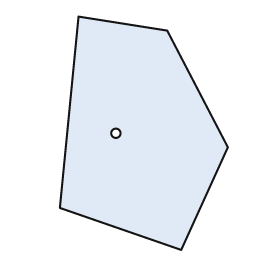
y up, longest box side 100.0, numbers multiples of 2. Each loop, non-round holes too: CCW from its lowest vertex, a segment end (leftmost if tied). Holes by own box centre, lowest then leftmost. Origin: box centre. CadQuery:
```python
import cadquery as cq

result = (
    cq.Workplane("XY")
    .moveTo(16.0, -50.0)
    .lineTo(36.0, -6.0)
    .lineTo(10.0, 44.0)
    .lineTo(-28.0, 50.0)
    .lineTo(-36.0, -32.0)
    .close()
    .moveTo(-12.0, 0.0)
    .circle(2.0)
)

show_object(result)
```